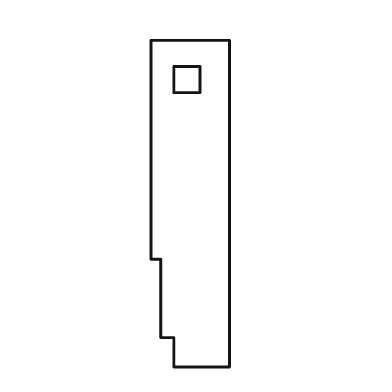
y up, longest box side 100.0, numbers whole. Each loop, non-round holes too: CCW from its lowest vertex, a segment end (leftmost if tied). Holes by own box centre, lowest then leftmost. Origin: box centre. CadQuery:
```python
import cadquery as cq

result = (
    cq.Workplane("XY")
    .moveTo(-5.0, -50.0)
    .lineTo(12.0, -50.0)
    .lineTo(12.0, 50.0)
    .lineTo(-12.0, 50.0)
    .lineTo(-12.0, -17.0)
    .lineTo(-9.0, -17.0)
    .lineTo(-9.0, -41.0)
    .lineTo(-5.0, -41.0)
    .close()
    .moveTo(-5.0, 34.0)
    .lineTo(3.0, 34.0)
    .lineTo(3.0, 42.0)
    .lineTo(-5.0, 42.0)
    .close()
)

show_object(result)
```